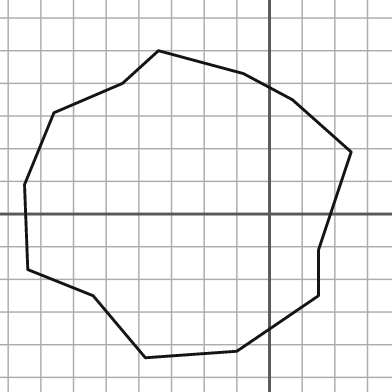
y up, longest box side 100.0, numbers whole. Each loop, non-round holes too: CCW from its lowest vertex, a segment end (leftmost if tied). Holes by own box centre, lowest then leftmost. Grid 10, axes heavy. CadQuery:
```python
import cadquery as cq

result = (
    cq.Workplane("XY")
    .moveTo(-38.0, -44.0)
    .lineTo(-10.0, -42.0)
    .lineTo(15.0, -25.0)
    .lineTo(15.0, -11.0)
    .lineTo(25.0, 19.0)
    .lineTo(7.0, 35.0)
    .lineTo(-8.0, 43.0)
    .lineTo(-34.0, 50.0)
    .lineTo(-45.0, 40.0)
    .lineTo(-66.0, 31.0)
    .lineTo(-75.0, 9.0)
    .lineTo(-74.0, -17.0)
    .lineTo(-54.0, -25.0)
    .close()
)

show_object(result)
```